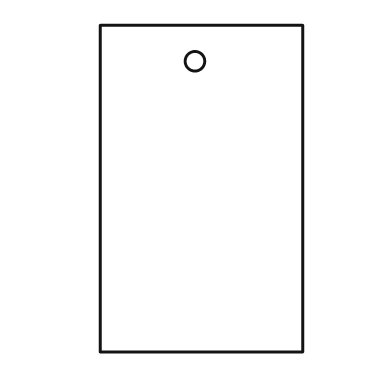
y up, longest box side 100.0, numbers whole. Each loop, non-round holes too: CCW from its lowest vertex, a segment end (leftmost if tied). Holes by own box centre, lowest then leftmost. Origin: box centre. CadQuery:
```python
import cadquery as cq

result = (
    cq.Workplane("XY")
    .moveTo(-31.0, -50.0)
    .lineTo(31.0, -50.0)
    .lineTo(31.0, 50.0)
    .lineTo(-31.0, 50.0)
    .close()
    .moveTo(-2.0, 39.0)
    .circle(3.0)
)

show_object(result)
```